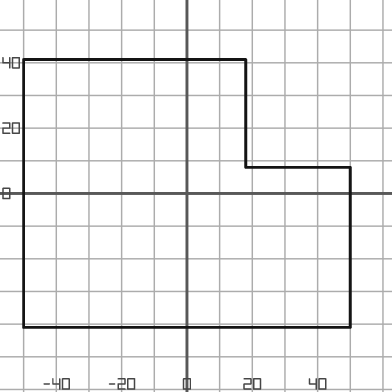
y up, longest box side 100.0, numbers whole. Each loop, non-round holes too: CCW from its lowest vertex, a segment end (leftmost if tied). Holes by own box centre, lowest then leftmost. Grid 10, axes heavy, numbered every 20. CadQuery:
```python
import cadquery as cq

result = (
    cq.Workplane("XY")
    .moveTo(-50.0, -41.0)
    .lineTo(50.0, -41.0)
    .lineTo(50.0, 8.0)
    .lineTo(18.0, 8.0)
    .lineTo(18.0, 41.0)
    .lineTo(-50.0, 41.0)
    .close()
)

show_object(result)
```